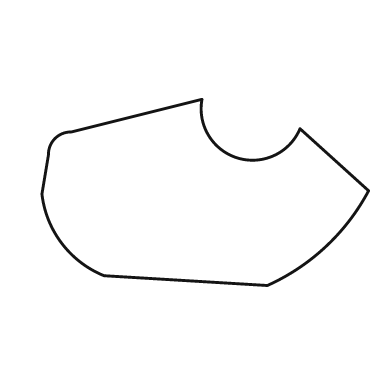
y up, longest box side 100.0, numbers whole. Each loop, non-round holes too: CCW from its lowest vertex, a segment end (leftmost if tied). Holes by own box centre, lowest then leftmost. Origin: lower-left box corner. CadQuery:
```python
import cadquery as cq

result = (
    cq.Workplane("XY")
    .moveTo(69.0, 0.0)
    .threePointArc((87.0, 12.0), (100.0, 29.0))
    .lineTo(79.0, 48.0)
    .threePointArc((60.0, 39.0), (49.0, 57.0))
    .lineTo(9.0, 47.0)
    .threePointArc((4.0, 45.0), (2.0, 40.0))
    .lineTo(0.0, 28.0)
    .threePointArc((6.0, 13.0), (19.0, 3.0))
    .close()
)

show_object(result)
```